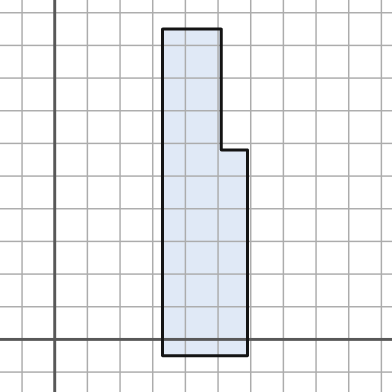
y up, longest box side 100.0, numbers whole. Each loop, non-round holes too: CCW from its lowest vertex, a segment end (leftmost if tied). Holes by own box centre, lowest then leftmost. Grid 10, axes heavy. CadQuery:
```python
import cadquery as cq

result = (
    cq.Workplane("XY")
    .moveTo(33.0, -5.0)
    .lineTo(59.0, -5.0)
    .lineTo(59.0, 58.0)
    .lineTo(51.0, 58.0)
    .lineTo(51.0, 95.0)
    .lineTo(33.0, 95.0)
    .close()
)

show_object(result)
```